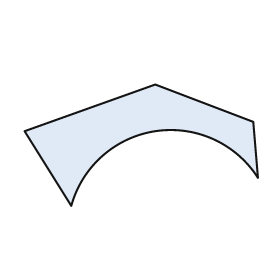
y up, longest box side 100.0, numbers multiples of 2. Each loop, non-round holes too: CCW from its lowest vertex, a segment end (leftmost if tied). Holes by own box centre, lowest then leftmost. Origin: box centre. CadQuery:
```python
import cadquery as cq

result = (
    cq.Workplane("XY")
    .moveTo(-30.0, -26.0)
    .threePointArc((6.0, 6.0), (50.0, -14.0))
    .lineTo(48.0, 10.0)
    .lineTo(6.0, 26.0)
    .lineTo(-50.0, 6.0)
    .close()
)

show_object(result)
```